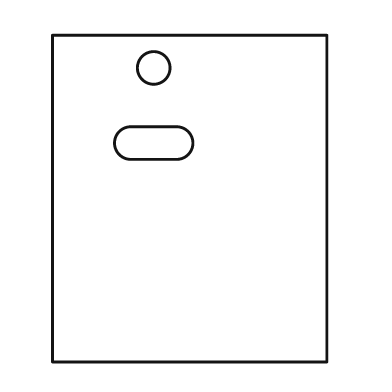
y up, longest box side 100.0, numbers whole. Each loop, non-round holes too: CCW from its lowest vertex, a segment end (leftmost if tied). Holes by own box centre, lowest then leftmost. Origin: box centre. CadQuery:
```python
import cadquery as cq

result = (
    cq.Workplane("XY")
    .moveTo(-42.0, -50.0)
    .lineTo(42.0, -50.0)
    .lineTo(42.0, 50.0)
    .lineTo(-42.0, 50.0)
    .close()
    .moveTo(-18.0, 12.0)
    .lineTo(-4.0, 12.0)
    .threePointArc((1.0, 17.0), (-4.0, 22.0))
    .lineTo(-18.0, 22.0)
    .threePointArc((-23.0, 17.0), (-18.0, 12.0))
    .close()
    .moveTo(-11.0, 40.0)
    .circle(5.0)
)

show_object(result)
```